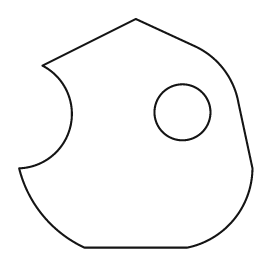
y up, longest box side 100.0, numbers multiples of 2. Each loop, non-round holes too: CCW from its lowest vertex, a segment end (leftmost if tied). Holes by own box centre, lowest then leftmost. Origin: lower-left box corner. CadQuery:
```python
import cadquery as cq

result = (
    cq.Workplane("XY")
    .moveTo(28.0, 0.0)
    .lineTo(72.0, 0.0)
    .threePointArc((92.0, 12.0), (100.0, 34.0))
    .lineTo(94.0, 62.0)
    .threePointArc((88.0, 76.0), (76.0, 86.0))
    .lineTo(50.0, 98.0)
    .lineTo(10.0, 78.0)
    .threePointArc((22.0, 52.0), (0.0, 34.0))
    .threePointArc((10.0, 14.0), (28.0, 0.0))
    .close()
    .moveTo(70.0, 58.0)
    .circle(12.0)
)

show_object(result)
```